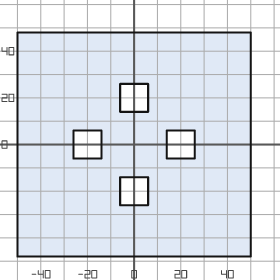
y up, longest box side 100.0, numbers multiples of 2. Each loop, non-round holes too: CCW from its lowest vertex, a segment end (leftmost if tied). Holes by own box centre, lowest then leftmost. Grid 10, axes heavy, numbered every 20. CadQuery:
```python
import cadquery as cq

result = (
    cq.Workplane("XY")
    .moveTo(-50.0, -48.0)
    .lineTo(50.0, -48.0)
    .lineTo(50.0, 48.0)
    .lineTo(-50.0, 48.0)
    .close()
    .moveTo(-6.0, -26.0)
    .lineTo(6.0, -26.0)
    .lineTo(6.0, -14.0)
    .lineTo(-6.0, -14.0)
    .close()
    .moveTo(-26.0, -6.0)
    .lineTo(-14.0, -6.0)
    .lineTo(-14.0, 6.0)
    .lineTo(-26.0, 6.0)
    .close()
    .moveTo(14.0, -6.0)
    .lineTo(26.0, -6.0)
    .lineTo(26.0, 6.0)
    .lineTo(14.0, 6.0)
    .close()
    .moveTo(-6.0, 14.0)
    .lineTo(6.0, 14.0)
    .lineTo(6.0, 26.0)
    .lineTo(-6.0, 26.0)
    .close()
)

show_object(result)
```